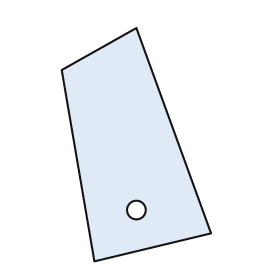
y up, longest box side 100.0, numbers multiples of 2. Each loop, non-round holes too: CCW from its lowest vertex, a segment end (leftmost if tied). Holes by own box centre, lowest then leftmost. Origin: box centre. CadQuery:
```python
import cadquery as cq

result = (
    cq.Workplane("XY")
    .moveTo(-18.0, -50.0)
    .lineTo(32.0, -38.0)
    .lineTo(0.0, 50.0)
    .lineTo(-32.0, 32.0)
    .close()
    .moveTo(0.0, -28.0)
    .circle(4.0)
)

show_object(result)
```